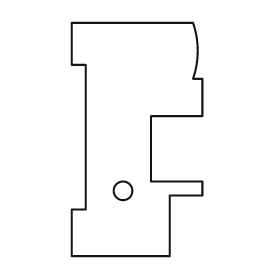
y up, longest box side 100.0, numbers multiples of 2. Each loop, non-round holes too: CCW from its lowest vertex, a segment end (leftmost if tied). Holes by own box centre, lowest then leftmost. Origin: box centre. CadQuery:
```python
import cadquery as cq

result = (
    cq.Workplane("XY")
    .moveTo(-28.0, -50.0)
    .lineTo(14.0, -50.0)
    .lineTo(14.0, -24.0)
    .lineTo(28.0, -24.0)
    .lineTo(28.0, -18.0)
    .lineTo(6.0, -18.0)
    .lineTo(6.0, 10.0)
    .lineTo(28.0, 10.0)
    .lineTo(28.0, 26.0)
    .lineTo(24.0, 26.0)
    .threePointArc((26.0, 38.0), (24.0, 50.0))
    .lineTo(-28.0, 50.0)
    .lineTo(-28.0, 32.0)
    .lineTo(-22.0, 32.0)
    .lineTo(-22.0, -30.0)
    .lineTo(-28.0, -30.0)
    .close()
    .moveTo(-6.0, -22.0)
    .circle(4.0)
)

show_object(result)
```